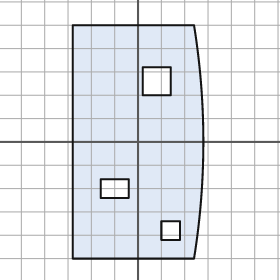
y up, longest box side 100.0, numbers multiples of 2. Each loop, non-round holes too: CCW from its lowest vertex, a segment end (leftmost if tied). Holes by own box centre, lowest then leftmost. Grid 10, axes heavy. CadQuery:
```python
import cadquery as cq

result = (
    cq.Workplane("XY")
    .moveTo(-28.0, -50.0)
    .lineTo(24.0, -50.0)
    .threePointArc((28.0, 0.0), (24.0, 50.0))
    .lineTo(-28.0, 50.0)
    .close()
    .moveTo(10.0, -42.0)
    .lineTo(18.0, -42.0)
    .lineTo(18.0, -34.0)
    .lineTo(10.0, -34.0)
    .close()
    .moveTo(-16.0, -24.0)
    .lineTo(-4.0, -24.0)
    .lineTo(-4.0, -16.0)
    .lineTo(-16.0, -16.0)
    .close()
    .moveTo(2.0, 20.0)
    .lineTo(14.0, 20.0)
    .lineTo(14.0, 32.0)
    .lineTo(2.0, 32.0)
    .close()
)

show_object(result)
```